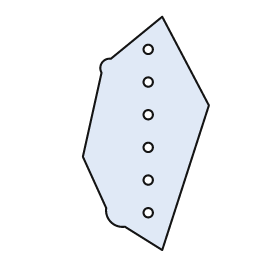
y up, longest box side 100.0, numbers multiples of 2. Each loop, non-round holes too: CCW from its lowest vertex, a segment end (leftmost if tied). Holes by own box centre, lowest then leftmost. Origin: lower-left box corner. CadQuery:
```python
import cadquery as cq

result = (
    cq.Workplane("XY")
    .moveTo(34.0, 0.0)
    .lineTo(54.0, 62.0)
    .lineTo(34.0, 100.0)
    .lineTo(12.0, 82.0)
    .threePointArc((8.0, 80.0), (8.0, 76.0))
    .lineTo(0.0, 40.0)
    .lineTo(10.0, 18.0)
    .threePointArc((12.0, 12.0), (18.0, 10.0))
    .close()
    .moveTo(28.0, 16.0)
    .circle(2.0)
    .moveTo(28.0, 30.0)
    .circle(2.0)
    .moveTo(28.0, 44.0)
    .circle(2.0)
    .moveTo(28.0, 58.0)
    .circle(2.0)
    .moveTo(28.0, 72.0)
    .circle(2.0)
    .moveTo(28.0, 86.0)
    .circle(2.0)
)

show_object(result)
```